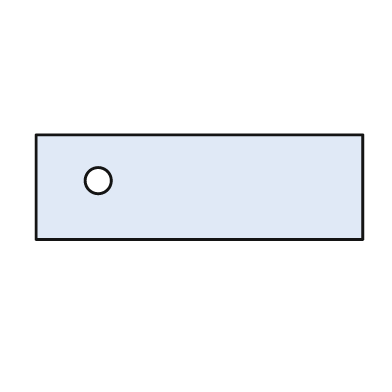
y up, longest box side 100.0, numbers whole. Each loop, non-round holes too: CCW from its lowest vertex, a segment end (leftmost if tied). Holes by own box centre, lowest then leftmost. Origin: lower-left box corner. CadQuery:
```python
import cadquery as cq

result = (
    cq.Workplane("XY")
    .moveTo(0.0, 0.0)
    .lineTo(100.0, 0.0)
    .lineTo(100.0, 32.0)
    .lineTo(0.0, 32.0)
    .close()
    .moveTo(19.0, 18.0)
    .circle(4.0)
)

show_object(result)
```